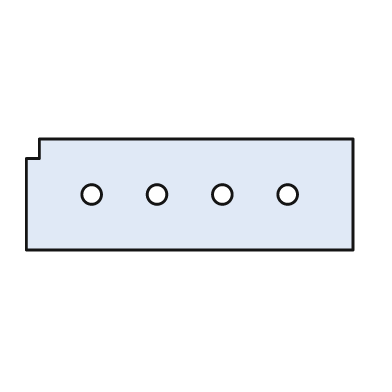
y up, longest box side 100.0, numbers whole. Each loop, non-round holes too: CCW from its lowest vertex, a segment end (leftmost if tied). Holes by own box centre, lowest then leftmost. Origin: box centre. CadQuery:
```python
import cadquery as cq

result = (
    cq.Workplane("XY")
    .moveTo(-50.0, -17.0)
    .lineTo(50.0, -17.0)
    .lineTo(50.0, 17.0)
    .lineTo(-46.0, 17.0)
    .lineTo(-46.0, 11.0)
    .lineTo(-50.0, 11.0)
    .close()
    .moveTo(-30.0, 0.0)
    .circle(3.0)
    .moveTo(-10.0, 0.0)
    .circle(3.0)
    .moveTo(10.0, 0.0)
    .circle(3.0)
    .moveTo(30.0, 0.0)
    .circle(3.0)
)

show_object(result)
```